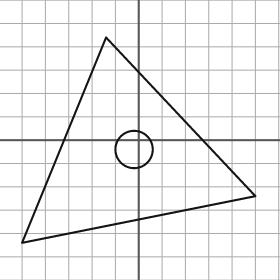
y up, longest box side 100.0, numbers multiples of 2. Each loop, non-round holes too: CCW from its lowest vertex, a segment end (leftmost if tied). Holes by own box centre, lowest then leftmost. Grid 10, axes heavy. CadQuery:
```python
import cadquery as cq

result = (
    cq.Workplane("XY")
    .moveTo(-50.0, -44.0)
    .lineTo(50.0, -24.0)
    .lineTo(-14.0, 44.0)
    .close()
    .moveTo(-2.0, -4.0)
    .circle(8.0)
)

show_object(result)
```